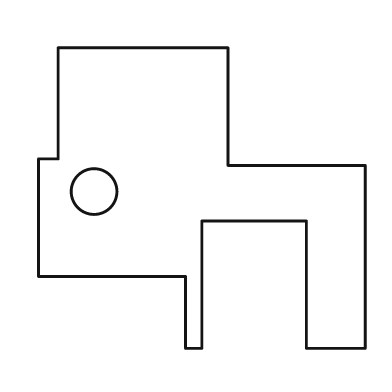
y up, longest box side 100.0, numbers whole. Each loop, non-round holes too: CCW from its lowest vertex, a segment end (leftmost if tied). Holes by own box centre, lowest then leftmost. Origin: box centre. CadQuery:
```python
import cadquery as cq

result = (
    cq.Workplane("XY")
    .moveTo(-5.0, -46.0)
    .lineTo(0.0, -46.0)
    .lineTo(0.0, -7.0)
    .lineTo(32.0, -7.0)
    .lineTo(32.0, -46.0)
    .lineTo(50.0, -46.0)
    .lineTo(50.0, 10.0)
    .lineTo(8.0, 10.0)
    .lineTo(8.0, 46.0)
    .lineTo(-44.0, 46.0)
    .lineTo(-44.0, 12.0)
    .lineTo(-50.0, 12.0)
    .lineTo(-50.0, -24.0)
    .lineTo(-5.0, -24.0)
    .close()
    .moveTo(-33.0, 2.0)
    .circle(7.0)
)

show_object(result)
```